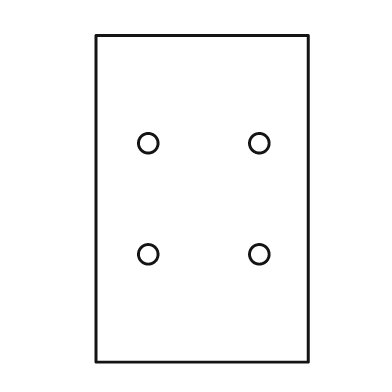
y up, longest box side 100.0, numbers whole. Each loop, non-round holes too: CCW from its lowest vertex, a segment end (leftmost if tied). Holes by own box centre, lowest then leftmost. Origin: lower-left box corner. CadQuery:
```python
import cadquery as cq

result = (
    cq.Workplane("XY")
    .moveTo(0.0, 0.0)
    .lineTo(65.0, 0.0)
    .lineTo(65.0, 100.0)
    .lineTo(0.0, 100.0)
    .close()
    .moveTo(16.0, 33.0)
    .circle(3.0)
    .moveTo(50.0, 33.0)
    .circle(3.0)
    .moveTo(16.0, 67.0)
    .circle(3.0)
    .moveTo(50.0, 67.0)
    .circle(3.0)
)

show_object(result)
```